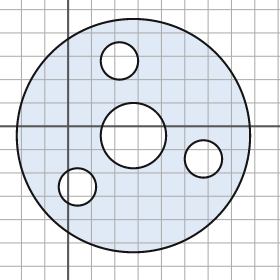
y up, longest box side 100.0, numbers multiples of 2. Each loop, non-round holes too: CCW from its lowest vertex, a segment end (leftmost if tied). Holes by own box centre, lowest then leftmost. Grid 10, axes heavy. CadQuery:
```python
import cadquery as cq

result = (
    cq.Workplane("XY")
    .moveTo(28.0, -4.0)
    .circle(50.0)
    .moveTo(4.0, -26.0)
    .circle(8.0)
    .moveTo(58.0, -14.0)
    .circle(8.0)
    .moveTo(28.0, -4.0)
    .circle(14.0)
    .moveTo(22.0, 28.0)
    .circle(8.0)
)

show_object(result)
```